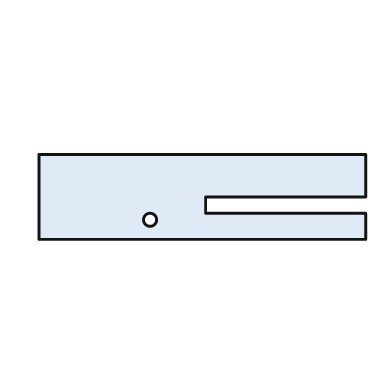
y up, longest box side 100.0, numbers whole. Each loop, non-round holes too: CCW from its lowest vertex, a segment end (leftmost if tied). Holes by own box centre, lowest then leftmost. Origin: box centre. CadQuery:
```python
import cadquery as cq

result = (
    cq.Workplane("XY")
    .moveTo(-50.0, -13.0)
    .lineTo(50.0, -13.0)
    .lineTo(50.0, -5.0)
    .lineTo(1.0, -5.0)
    .lineTo(1.0, 0.0)
    .lineTo(50.0, 0.0)
    .lineTo(50.0, 13.0)
    .lineTo(-50.0, 13.0)
    .close()
    .moveTo(-16.0, -7.0)
    .circle(2.0)
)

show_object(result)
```